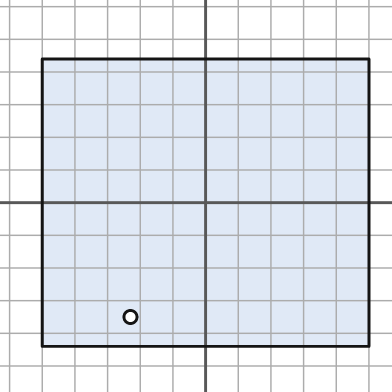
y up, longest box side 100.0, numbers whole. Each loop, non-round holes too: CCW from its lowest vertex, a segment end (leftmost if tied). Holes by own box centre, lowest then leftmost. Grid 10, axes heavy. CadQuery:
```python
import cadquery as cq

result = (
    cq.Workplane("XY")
    .moveTo(-50.0, -44.0)
    .lineTo(50.0, -44.0)
    .lineTo(50.0, 44.0)
    .lineTo(-50.0, 44.0)
    .close()
    .moveTo(-23.0, -35.0)
    .circle(2.0)
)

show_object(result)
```